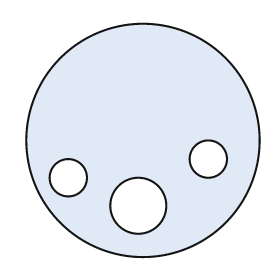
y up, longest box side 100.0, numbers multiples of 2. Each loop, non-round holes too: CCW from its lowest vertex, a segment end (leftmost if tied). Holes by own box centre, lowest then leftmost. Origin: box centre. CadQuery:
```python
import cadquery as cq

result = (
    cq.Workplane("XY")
    .moveTo(0.0, 0.0)
    .circle(50.0)
    .moveTo(-2.0, -28.0)
    .circle(12.0)
    .moveTo(-32.0, -16.0)
    .circle(8.0)
    .moveTo(28.0, -8.0)
    .circle(8.0)
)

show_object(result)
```